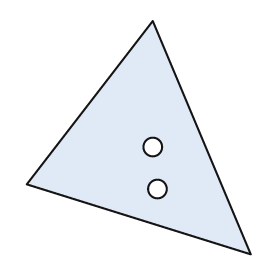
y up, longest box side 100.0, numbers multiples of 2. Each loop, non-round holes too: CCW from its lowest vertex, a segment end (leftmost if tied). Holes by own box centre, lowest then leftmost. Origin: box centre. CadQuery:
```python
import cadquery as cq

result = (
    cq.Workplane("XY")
    .moveTo(48.0, -50.0)
    .lineTo(6.0, 50.0)
    .lineTo(-48.0, -20.0)
    .close()
    .moveTo(8.0, -22.0)
    .circle(4.0)
    .moveTo(6.0, -4.0)
    .circle(4.0)
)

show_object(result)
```